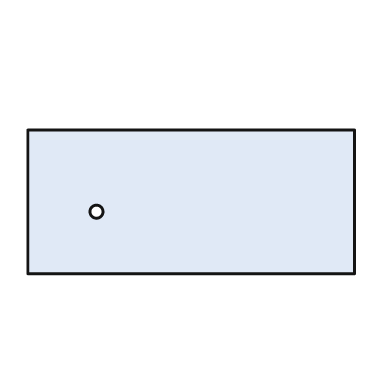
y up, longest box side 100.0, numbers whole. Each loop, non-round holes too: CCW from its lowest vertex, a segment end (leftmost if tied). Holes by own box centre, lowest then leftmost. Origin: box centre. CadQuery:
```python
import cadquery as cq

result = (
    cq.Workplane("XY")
    .moveTo(-50.0, -22.0)
    .lineTo(50.0, -22.0)
    .lineTo(50.0, 22.0)
    .lineTo(-50.0, 22.0)
    .close()
    .moveTo(-29.0, -3.0)
    .circle(2.0)
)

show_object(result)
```